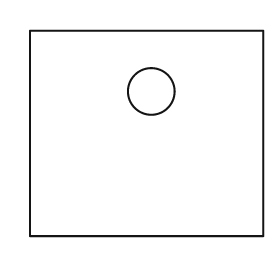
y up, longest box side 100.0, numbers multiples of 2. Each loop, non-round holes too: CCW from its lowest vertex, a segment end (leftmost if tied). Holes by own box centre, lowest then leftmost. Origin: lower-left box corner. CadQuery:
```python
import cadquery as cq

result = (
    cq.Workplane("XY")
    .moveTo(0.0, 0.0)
    .lineTo(100.0, 0.0)
    .lineTo(100.0, 88.0)
    .lineTo(0.0, 88.0)
    .close()
    .moveTo(52.0, 62.0)
    .circle(10.0)
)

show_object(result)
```